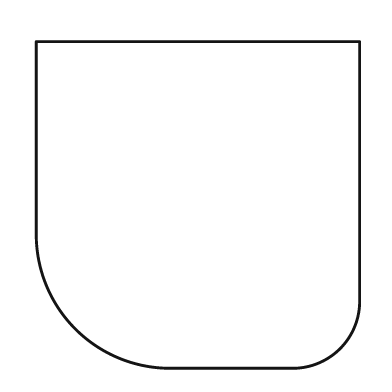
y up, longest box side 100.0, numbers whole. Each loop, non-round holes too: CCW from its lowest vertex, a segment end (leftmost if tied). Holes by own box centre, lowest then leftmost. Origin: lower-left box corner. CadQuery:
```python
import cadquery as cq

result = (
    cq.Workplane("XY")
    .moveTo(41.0, 0.0)
    .lineTo(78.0, 0.0)
    .threePointArc((93.0, 6.0), (99.0, 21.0))
    .lineTo(99.0, 100.0)
    .lineTo(0.0, 100.0)
    .lineTo(0.0, 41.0)
    .threePointArc((12.0, 12.0), (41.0, 0.0))
    .close()
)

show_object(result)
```